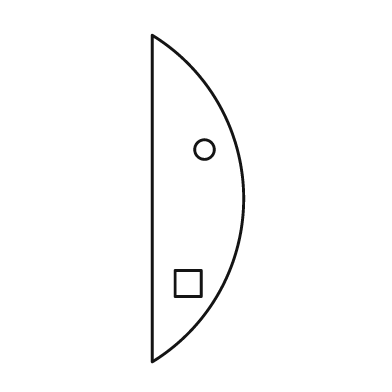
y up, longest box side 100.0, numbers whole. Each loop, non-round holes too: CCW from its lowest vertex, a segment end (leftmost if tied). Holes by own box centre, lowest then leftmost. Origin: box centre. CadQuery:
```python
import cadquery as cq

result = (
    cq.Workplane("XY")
    .moveTo(-14.0, -50.0)
    .threePointArc((14.0, 0.0), (-14.0, 50.0))
    .close()
    .moveTo(-7.0, -30.0)
    .lineTo(1.0, -30.0)
    .lineTo(1.0, -22.0)
    .lineTo(-7.0, -22.0)
    .close()
    .moveTo(2.0, 15.0)
    .circle(3.0)
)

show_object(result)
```